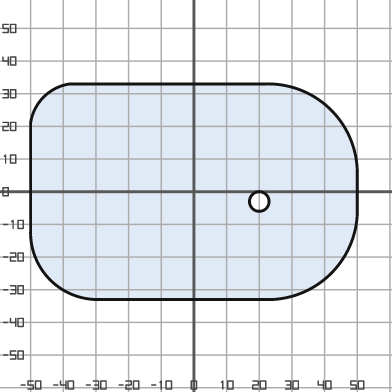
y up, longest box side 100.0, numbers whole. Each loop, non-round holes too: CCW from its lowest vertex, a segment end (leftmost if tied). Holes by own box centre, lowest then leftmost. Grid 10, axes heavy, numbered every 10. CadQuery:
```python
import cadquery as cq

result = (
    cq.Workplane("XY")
    .moveTo(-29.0, -33.0)
    .lineTo(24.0, -33.0)
    .threePointArc((42.0, -25.0), (50.0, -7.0))
    .lineTo(50.0, 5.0)
    .threePointArc((42.0, 25.0), (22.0, 33.0))
    .lineTo(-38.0, 33.0)
    .threePointArc((-46.0, 29.0), (-50.0, 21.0))
    .lineTo(-50.0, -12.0)
    .threePointArc((-44.0, -27.0), (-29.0, -33.0))
    .close()
    .moveTo(20.0, -3.0)
    .circle(3.0)
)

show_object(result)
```